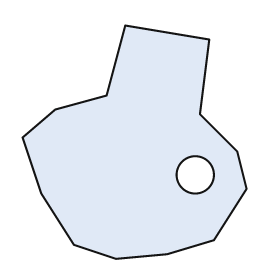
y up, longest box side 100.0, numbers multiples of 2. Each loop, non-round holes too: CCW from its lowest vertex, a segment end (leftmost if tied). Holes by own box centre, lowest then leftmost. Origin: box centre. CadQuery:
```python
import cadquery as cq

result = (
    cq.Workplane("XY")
    .moveTo(-8.0, -50.0)
    .lineTo(14.0, -48.0)
    .lineTo(34.0, -42.0)
    .lineTo(48.0, -20.0)
    .lineTo(44.0, -4.0)
    .lineTo(28.0, 12.0)
    .lineTo(32.0, 44.0)
    .lineTo(-4.0, 50.0)
    .lineTo(-12.0, 20.0)
    .lineTo(-34.0, 14.0)
    .lineTo(-48.0, 2.0)
    .lineTo(-40.0, -22.0)
    .lineTo(-26.0, -44.0)
    .close()
    .moveTo(26.0, -14.0)
    .circle(8.0)
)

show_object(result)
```